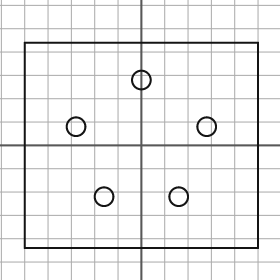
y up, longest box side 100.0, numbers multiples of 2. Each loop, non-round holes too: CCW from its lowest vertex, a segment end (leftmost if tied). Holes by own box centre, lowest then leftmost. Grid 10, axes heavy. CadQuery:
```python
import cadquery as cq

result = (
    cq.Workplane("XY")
    .moveTo(-50.0, -44.0)
    .lineTo(50.0, -44.0)
    .lineTo(50.0, 44.0)
    .lineTo(-50.0, 44.0)
    .close()
    .moveTo(-16.0, -22.0)
    .circle(4.0)
    .moveTo(16.0, -22.0)
    .circle(4.0)
    .moveTo(-28.0, 8.0)
    .circle(4.0)
    .moveTo(28.0, 8.0)
    .circle(4.0)
    .moveTo(0.0, 28.0)
    .circle(4.0)
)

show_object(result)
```